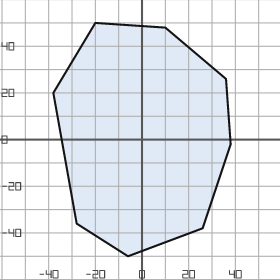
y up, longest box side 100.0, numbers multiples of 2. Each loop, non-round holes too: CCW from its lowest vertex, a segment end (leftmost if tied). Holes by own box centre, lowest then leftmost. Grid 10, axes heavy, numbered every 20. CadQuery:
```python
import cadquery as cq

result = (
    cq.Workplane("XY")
    .moveTo(-6.0, -50.0)
    .lineTo(26.0, -38.0)
    .lineTo(38.0, -2.0)
    .lineTo(36.0, 26.0)
    .lineTo(10.0, 48.0)
    .lineTo(-20.0, 50.0)
    .lineTo(-38.0, 20.0)
    .lineTo(-28.0, -36.0)
    .close()
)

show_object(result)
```